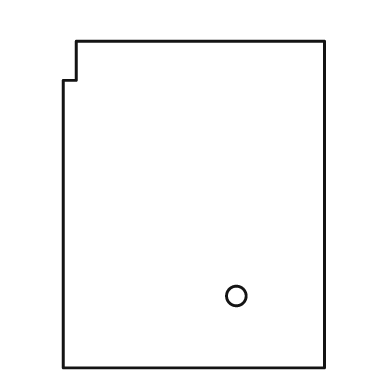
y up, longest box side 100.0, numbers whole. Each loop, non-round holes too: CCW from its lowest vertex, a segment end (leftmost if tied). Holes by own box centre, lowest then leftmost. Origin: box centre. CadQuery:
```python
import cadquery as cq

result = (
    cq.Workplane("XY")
    .moveTo(-40.0, -50.0)
    .lineTo(40.0, -50.0)
    .lineTo(40.0, 50.0)
    .lineTo(-36.0, 50.0)
    .lineTo(-36.0, 38.0)
    .lineTo(-40.0, 38.0)
    .close()
    .moveTo(13.0, -28.0)
    .circle(3.0)
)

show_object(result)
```